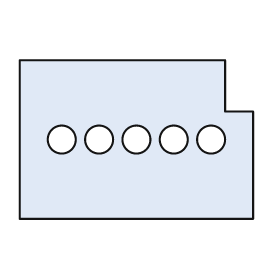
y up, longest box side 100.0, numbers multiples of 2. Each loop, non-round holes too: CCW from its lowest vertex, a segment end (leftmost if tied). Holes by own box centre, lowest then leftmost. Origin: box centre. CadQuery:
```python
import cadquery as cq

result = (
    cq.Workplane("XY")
    .moveTo(-50.0, -34.0)
    .lineTo(50.0, -34.0)
    .lineTo(50.0, 12.0)
    .lineTo(38.0, 12.0)
    .lineTo(38.0, 34.0)
    .lineTo(-50.0, 34.0)
    .close()
    .moveTo(-32.0, 0.0)
    .circle(6.0)
    .moveTo(-16.0, 0.0)
    .circle(6.0)
    .moveTo(0.0, 0.0)
    .circle(6.0)
    .moveTo(16.0, 0.0)
    .circle(6.0)
    .moveTo(32.0, 0.0)
    .circle(6.0)
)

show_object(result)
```